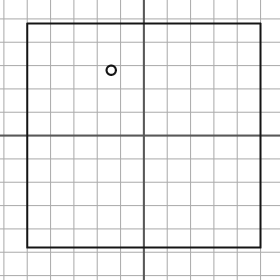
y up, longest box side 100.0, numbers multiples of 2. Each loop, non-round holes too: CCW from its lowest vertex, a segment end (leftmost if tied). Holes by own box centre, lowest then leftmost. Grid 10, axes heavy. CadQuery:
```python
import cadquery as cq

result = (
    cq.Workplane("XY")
    .moveTo(-50.0, -48.0)
    .lineTo(50.0, -48.0)
    .lineTo(50.0, 48.0)
    .lineTo(-50.0, 48.0)
    .close()
    .moveTo(-14.0, 28.0)
    .circle(2.0)
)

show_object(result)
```